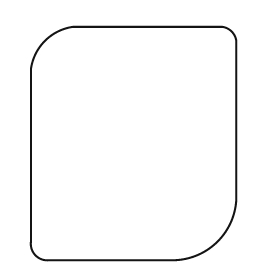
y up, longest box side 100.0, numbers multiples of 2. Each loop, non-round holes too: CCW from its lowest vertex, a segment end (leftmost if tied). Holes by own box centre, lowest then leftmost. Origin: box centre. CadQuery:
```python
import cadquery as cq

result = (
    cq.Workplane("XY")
    .moveTo(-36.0, -50.0)
    .lineTo(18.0, -50.0)
    .threePointArc((36.0, -42.0), (44.0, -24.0))
    .lineTo(44.0, 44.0)
    .threePointArc((42.0, 48.0), (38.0, 50.0))
    .lineTo(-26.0, 50.0)
    .threePointArc((-38.0, 44.0), (-44.0, 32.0))
    .lineTo(-44.0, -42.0)
    .threePointArc((-42.0, -48.0), (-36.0, -50.0))
    .close()
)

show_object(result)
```